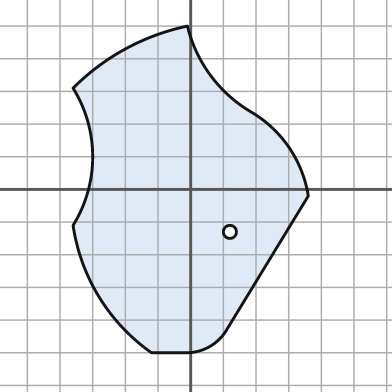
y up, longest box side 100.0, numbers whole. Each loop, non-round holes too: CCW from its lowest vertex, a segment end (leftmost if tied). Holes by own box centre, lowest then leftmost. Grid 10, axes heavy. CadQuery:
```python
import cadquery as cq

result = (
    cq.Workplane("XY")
    .moveTo(-12.0, -50.0)
    .lineTo(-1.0, -50.0)
    .threePointArc((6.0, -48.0), (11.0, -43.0))
    .lineTo(36.0, -2.0)
    .threePointArc((30.0, 13.0), (18.0, 24.0))
    .threePointArc((6.0, 35.0), (-1.0, 50.0))
    .threePointArc((-20.0, 43.0), (-36.0, 31.0))
    .threePointArc((-30.0, 10.0), (-36.0, -11.0))
    .threePointArc((-28.0, -33.0), (-12.0, -50.0))
    .close()
    .moveTo(12.0, -13.0)
    .circle(2.0)
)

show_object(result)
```